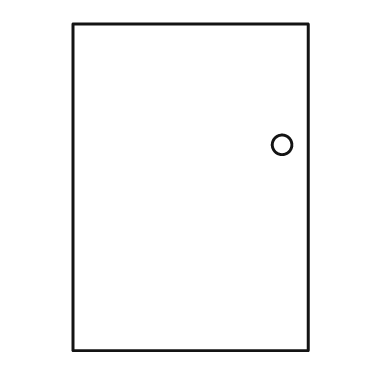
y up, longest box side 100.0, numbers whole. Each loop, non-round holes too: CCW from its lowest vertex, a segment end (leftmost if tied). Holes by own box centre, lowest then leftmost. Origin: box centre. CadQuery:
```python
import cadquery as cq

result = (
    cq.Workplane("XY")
    .moveTo(-36.0, -50.0)
    .lineTo(36.0, -50.0)
    .lineTo(36.0, 50.0)
    .lineTo(-36.0, 50.0)
    .close()
    .moveTo(28.0, 13.0)
    .circle(3.0)
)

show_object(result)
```